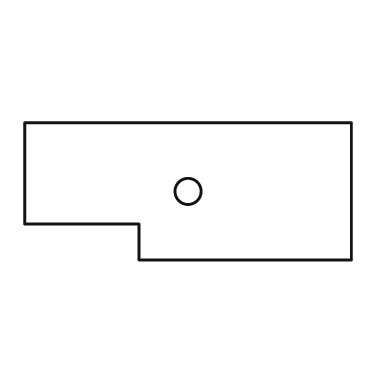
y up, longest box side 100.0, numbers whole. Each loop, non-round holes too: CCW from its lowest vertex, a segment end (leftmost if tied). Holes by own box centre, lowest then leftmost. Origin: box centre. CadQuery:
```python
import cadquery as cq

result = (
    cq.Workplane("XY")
    .moveTo(-15.0, -21.0)
    .lineTo(50.0, -21.0)
    .lineTo(50.0, 21.0)
    .lineTo(-50.0, 21.0)
    .lineTo(-50.0, -10.0)
    .lineTo(-15.0, -10.0)
    .close()
    .moveTo(0.0, 0.0)
    .circle(4.0)
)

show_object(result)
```